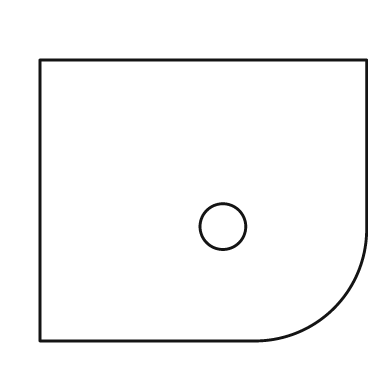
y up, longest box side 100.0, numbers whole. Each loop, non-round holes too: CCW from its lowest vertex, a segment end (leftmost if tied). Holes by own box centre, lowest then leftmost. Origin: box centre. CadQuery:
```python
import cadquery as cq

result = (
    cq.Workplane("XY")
    .moveTo(-50.0, -43.0)
    .lineTo(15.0, -43.0)
    .threePointArc((40.0, -33.0), (50.0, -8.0))
    .lineTo(50.0, 43.0)
    .lineTo(-50.0, 43.0)
    .close()
    .moveTo(6.0, -8.0)
    .circle(7.0)
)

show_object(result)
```